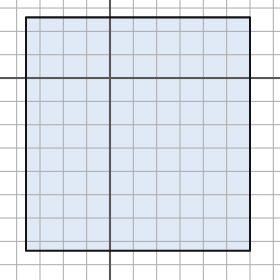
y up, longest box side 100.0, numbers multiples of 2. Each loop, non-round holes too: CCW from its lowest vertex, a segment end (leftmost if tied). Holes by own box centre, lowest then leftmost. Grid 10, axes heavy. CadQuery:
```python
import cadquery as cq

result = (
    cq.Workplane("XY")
    .moveTo(-36.0, -74.0)
    .lineTo(60.0, -74.0)
    .lineTo(60.0, 26.0)
    .lineTo(-36.0, 26.0)
    .close()
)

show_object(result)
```